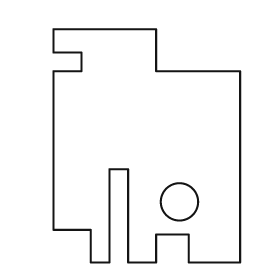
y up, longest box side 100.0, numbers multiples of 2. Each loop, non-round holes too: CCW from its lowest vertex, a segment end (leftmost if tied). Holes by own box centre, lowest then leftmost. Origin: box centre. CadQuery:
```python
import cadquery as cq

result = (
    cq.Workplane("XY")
    .moveTo(-24.0, -50.0)
    .lineTo(-16.0, -50.0)
    .lineTo(-16.0, -10.0)
    .lineTo(-8.0, -10.0)
    .lineTo(-8.0, -50.0)
    .lineTo(4.0, -50.0)
    .lineTo(4.0, -38.0)
    .lineTo(18.0, -38.0)
    .lineTo(18.0, -50.0)
    .lineTo(40.0, -50.0)
    .lineTo(40.0, 32.0)
    .lineTo(4.0, 32.0)
    .lineTo(4.0, 50.0)
    .lineTo(-40.0, 50.0)
    .lineTo(-40.0, 40.0)
    .lineTo(-28.0, 40.0)
    .lineTo(-28.0, 32.0)
    .lineTo(-40.0, 32.0)
    .lineTo(-40.0, -36.0)
    .lineTo(-24.0, -36.0)
    .close()
    .moveTo(14.0, -24.0)
    .circle(8.0)
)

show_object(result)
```